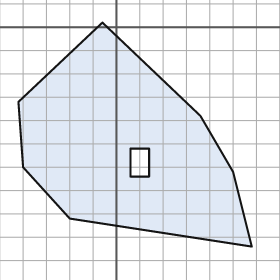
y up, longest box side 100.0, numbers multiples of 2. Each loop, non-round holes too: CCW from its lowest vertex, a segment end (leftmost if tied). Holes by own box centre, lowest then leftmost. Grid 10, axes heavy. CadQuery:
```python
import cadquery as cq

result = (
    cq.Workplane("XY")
    .moveTo(58.0, -94.0)
    .lineTo(50.0, -62.0)
    .lineTo(36.0, -38.0)
    .lineTo(-6.0, 2.0)
    .lineTo(-42.0, -32.0)
    .lineTo(-40.0, -60.0)
    .lineTo(-20.0, -82.0)
    .close()
    .moveTo(6.0, -64.0)
    .lineTo(14.0, -64.0)
    .lineTo(14.0, -52.0)
    .lineTo(6.0, -52.0)
    .close()
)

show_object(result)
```